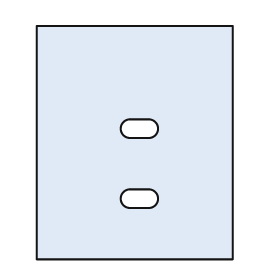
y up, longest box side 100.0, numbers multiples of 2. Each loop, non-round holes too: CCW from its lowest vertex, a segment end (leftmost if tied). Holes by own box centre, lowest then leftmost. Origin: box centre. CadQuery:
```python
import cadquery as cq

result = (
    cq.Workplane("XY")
    .moveTo(-42.0, -50.0)
    .lineTo(42.0, -50.0)
    .lineTo(42.0, 50.0)
    .lineTo(-42.0, 50.0)
    .close()
    .moveTo(-2.0, -28.0)
    .lineTo(6.0, -28.0)
    .threePointArc((10.0, -24.0), (6.0, -20.0))
    .lineTo(-2.0, -20.0)
    .threePointArc((-6.0, -24.0), (-2.0, -28.0))
    .close()
    .moveTo(-2.0, 2.0)
    .lineTo(6.0, 2.0)
    .threePointArc((10.0, 6.0), (6.0, 10.0))
    .lineTo(-2.0, 10.0)
    .threePointArc((-6.0, 6.0), (-2.0, 2.0))
    .close()
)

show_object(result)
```